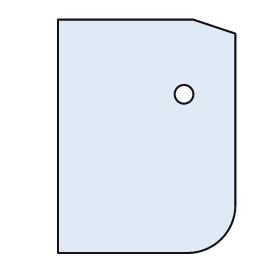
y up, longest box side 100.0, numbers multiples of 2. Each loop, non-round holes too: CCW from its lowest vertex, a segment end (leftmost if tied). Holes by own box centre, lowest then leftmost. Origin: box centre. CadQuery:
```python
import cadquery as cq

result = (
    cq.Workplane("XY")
    .moveTo(-38.0, -50.0)
    .lineTo(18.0, -50.0)
    .threePointArc((32.0, -44.0), (38.0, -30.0))
    .lineTo(38.0, 44.0)
    .lineTo(20.0, 50.0)
    .lineTo(-38.0, 50.0)
    .close()
    .moveTo(16.0, 18.0)
    .circle(4.0)
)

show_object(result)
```